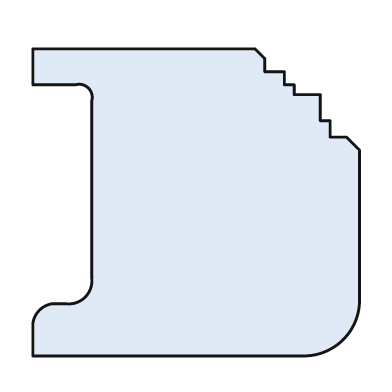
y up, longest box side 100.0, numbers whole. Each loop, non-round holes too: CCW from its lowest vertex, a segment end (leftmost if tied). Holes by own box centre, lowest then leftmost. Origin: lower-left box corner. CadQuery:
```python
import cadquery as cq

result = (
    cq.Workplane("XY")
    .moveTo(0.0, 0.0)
    .lineTo(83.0, 0.0)
    .threePointArc((95.0, 5.0), (100.0, 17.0))
    .lineTo(100.0, 63.0)
    .lineTo(96.0, 67.0)
    .lineTo(91.0, 67.0)
    .lineTo(91.0, 72.0)
    .lineTo(88.0, 72.0)
    .lineTo(88.0, 80.0)
    .lineTo(80.0, 80.0)
    .lineTo(80.0, 83.0)
    .lineTo(77.0, 83.0)
    .lineTo(77.0, 87.0)
    .lineTo(71.0, 87.0)
    .lineTo(71.0, 91.0)
    .lineTo(68.0, 94.0)
    .lineTo(0.0, 94.0)
    .lineTo(0.0, 83.0)
    .lineTo(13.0, 83.0)
    .threePointArc((17.0, 82.0), (18.0, 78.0))
    .lineTo(18.0, 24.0)
    .threePointArc((16.0, 18.0), (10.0, 16.0))
    .lineTo(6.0, 16.0)
    .threePointArc((2.0, 14.0), (0.0, 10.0))
    .close()
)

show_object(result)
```